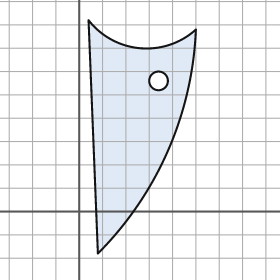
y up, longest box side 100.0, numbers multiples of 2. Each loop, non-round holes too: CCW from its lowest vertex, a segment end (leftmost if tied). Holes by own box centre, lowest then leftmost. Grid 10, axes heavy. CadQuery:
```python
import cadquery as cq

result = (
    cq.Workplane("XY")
    .moveTo(8.0, -18.0)
    .threePointArc((38.0, 26.0), (50.0, 78.0))
    .threePointArc((26.0, 70.0), (4.0, 82.0))
    .close()
    .moveTo(34.0, 56.0)
    .circle(4.0)
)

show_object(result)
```